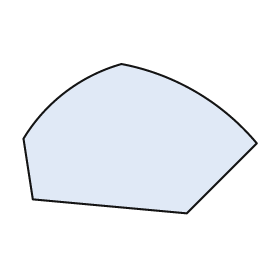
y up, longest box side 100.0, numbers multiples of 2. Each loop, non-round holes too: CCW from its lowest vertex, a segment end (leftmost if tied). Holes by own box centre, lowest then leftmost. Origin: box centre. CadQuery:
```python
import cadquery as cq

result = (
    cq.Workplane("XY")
    .moveTo(20.0, -32.0)
    .lineTo(50.0, -2.0)
    .threePointArc((24.0, 20.0), (-8.0, 32.0))
    .threePointArc((-32.0, 20.0), (-50.0, 0.0))
    .lineTo(-46.0, -26.0)
    .close()
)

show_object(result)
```